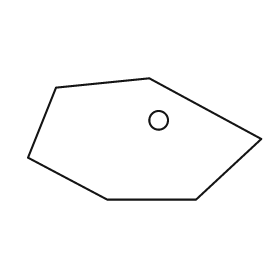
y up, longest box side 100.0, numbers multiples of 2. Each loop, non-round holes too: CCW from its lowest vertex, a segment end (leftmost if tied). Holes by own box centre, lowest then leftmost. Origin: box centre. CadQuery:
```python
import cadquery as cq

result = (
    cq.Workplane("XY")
    .moveTo(-16.0, -26.0)
    .lineTo(22.0, -26.0)
    .lineTo(50.0, 0.0)
    .lineTo(2.0, 26.0)
    .lineTo(-38.0, 22.0)
    .lineTo(-50.0, -8.0)
    .close()
    .moveTo(6.0, 8.0)
    .circle(4.0)
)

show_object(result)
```